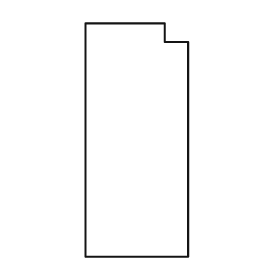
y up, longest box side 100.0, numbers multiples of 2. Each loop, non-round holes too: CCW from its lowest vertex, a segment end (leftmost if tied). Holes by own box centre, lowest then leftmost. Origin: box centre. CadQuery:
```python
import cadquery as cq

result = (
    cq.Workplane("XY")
    .moveTo(-22.0, -50.0)
    .lineTo(22.0, -50.0)
    .lineTo(22.0, 42.0)
    .lineTo(12.0, 42.0)
    .lineTo(12.0, 50.0)
    .lineTo(-22.0, 50.0)
    .close()
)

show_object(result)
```